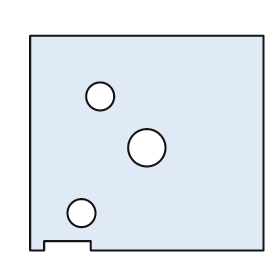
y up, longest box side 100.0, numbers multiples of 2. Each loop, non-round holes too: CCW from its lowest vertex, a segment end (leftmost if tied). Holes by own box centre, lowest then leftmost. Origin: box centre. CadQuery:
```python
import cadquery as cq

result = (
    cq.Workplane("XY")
    .moveTo(-50.0, -46.0)
    .lineTo(-44.0, -46.0)
    .lineTo(-44.0, -42.0)
    .lineTo(-24.0, -42.0)
    .lineTo(-24.0, -46.0)
    .lineTo(50.0, -46.0)
    .lineTo(50.0, 46.0)
    .lineTo(-50.0, 46.0)
    .close()
    .moveTo(-28.0, -30.0)
    .circle(6.0)
    .moveTo(0.0, -2.0)
    .circle(8.0)
    .moveTo(-20.0, 20.0)
    .circle(6.0)
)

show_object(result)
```